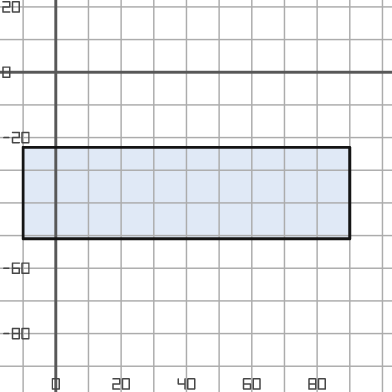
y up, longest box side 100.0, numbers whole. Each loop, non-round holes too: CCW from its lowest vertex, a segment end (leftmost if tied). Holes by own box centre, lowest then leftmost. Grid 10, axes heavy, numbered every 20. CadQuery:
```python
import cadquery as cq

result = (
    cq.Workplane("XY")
    .moveTo(-10.0, -51.0)
    .lineTo(90.0, -51.0)
    .lineTo(90.0, -23.0)
    .lineTo(-10.0, -23.0)
    .close()
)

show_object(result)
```